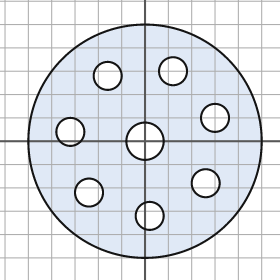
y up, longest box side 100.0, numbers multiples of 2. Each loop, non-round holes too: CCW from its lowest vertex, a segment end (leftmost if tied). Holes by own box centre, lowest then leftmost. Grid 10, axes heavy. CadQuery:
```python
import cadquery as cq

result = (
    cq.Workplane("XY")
    .moveTo(0.0, 0.0)
    .circle(50.0)
    .moveTo(2.0, -32.0)
    .circle(6.0)
    .moveTo(-24.0, -22.0)
    .circle(6.0)
    .moveTo(26.0, -18.0)
    .circle(6.0)
    .moveTo(0.0, 0.0)
    .circle(8.0)
    .moveTo(-32.0, 4.0)
    .circle(6.0)
    .moveTo(30.0, 10.0)
    .circle(6.0)
    .moveTo(-16.0, 28.0)
    .circle(6.0)
    .moveTo(12.0, 30.0)
    .circle(6.0)
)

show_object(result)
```